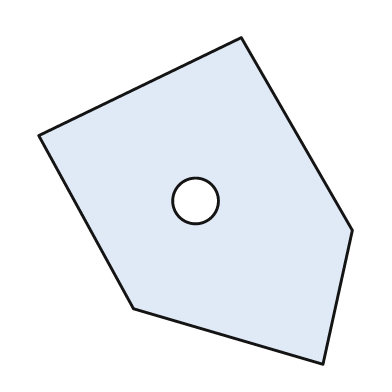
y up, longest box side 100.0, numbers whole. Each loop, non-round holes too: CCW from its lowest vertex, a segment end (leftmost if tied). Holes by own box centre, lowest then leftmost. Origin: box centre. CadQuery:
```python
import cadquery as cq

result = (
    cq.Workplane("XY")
    .moveTo(39.0, -50.0)
    .lineTo(48.0, -9.0)
    .lineTo(14.0, 50.0)
    .lineTo(-48.0, 20.0)
    .lineTo(-19.0, -33.0)
    .close()
    .moveTo(0.0, 0.0)
    .circle(7.0)
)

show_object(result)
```